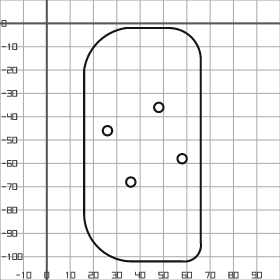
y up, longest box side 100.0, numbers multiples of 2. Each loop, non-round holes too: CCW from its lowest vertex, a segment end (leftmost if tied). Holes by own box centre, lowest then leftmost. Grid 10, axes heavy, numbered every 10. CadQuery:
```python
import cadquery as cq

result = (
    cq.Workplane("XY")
    .moveTo(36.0, -102.0)
    .lineTo(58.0, -102.0)
    .threePointArc((64.0, -100.0), (66.0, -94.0))
    .lineTo(66.0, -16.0)
    .threePointArc((62.0, -6.0), (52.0, -2.0))
    .lineTo(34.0, -2.0)
    .threePointArc((22.0, -8.0), (16.0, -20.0))
    .lineTo(16.0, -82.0)
    .threePointArc((22.0, -96.0), (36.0, -102.0))
    .close()
    .moveTo(36.0, -68.0)
    .circle(2.0)
    .moveTo(58.0, -58.0)
    .circle(2.0)
    .moveTo(26.0, -46.0)
    .circle(2.0)
    .moveTo(48.0, -36.0)
    .circle(2.0)
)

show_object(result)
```